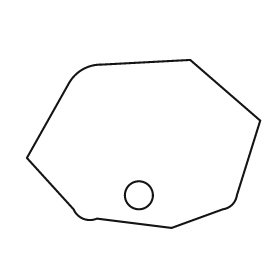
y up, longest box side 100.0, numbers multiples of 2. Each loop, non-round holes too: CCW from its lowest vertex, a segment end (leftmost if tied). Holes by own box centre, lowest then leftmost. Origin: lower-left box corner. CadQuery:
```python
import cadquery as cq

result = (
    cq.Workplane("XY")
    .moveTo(62.0, 0.0)
    .lineTo(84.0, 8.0)
    .threePointArc((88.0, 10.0), (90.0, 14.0))
    .lineTo(100.0, 46.0)
    .lineTo(70.0, 72.0)
    .lineTo(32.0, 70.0)
    .threePointArc((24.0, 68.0), (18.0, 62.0))
    .lineTo(0.0, 30.0)
    .lineTo(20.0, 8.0)
    .threePointArc((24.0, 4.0), (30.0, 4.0))
    .close()
    .moveTo(48.0, 14.0)
    .circle(6.0)
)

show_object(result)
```